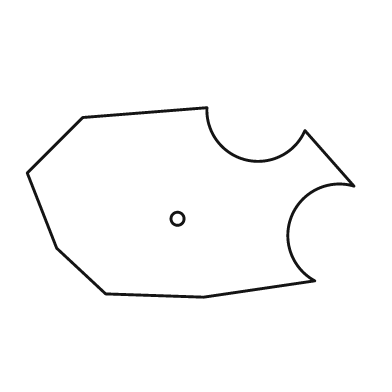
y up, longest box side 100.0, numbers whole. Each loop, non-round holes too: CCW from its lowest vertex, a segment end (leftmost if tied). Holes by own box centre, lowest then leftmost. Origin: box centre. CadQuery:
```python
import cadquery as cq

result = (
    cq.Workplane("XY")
    .moveTo(4.0, -29.0)
    .lineTo(38.0, -24.0)
    .threePointArc((31.0, -4.0), (50.0, 5.0))
    .lineTo(35.0, 22.0)
    .threePointArc((17.0, 13.0), (5.0, 29.0))
    .lineTo(-33.0, 26.0)
    .lineTo(-50.0, 9.0)
    .lineTo(-41.0, -14.0)
    .lineTo(-26.0, -28.0)
    .close()
    .moveTo(-4.0, -5.0)
    .circle(2.0)
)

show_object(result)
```